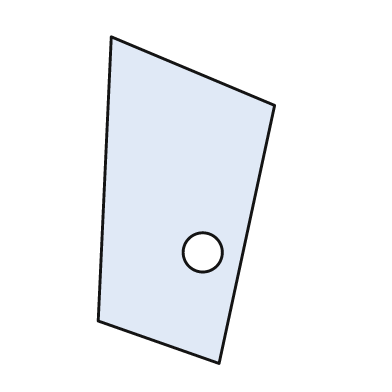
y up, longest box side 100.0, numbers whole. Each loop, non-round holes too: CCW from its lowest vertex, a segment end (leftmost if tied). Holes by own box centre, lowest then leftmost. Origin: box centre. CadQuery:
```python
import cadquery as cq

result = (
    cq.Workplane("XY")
    .moveTo(10.0, -50.0)
    .lineTo(27.0, 29.0)
    .lineTo(-23.0, 50.0)
    .lineTo(-27.0, -37.0)
    .close()
    .moveTo(5.0, -16.0)
    .circle(6.0)
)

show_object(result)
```